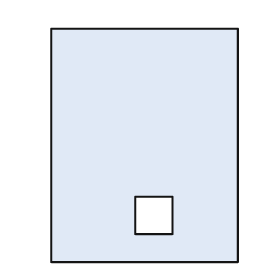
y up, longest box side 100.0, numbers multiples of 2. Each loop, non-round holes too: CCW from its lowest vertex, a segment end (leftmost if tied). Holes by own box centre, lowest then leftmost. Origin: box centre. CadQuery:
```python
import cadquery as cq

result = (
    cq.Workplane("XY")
    .moveTo(-40.0, -50.0)
    .lineTo(40.0, -50.0)
    .lineTo(40.0, 50.0)
    .lineTo(-40.0, 50.0)
    .close()
    .moveTo(-4.0, -38.0)
    .lineTo(12.0, -38.0)
    .lineTo(12.0, -22.0)
    .lineTo(-4.0, -22.0)
    .close()
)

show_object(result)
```